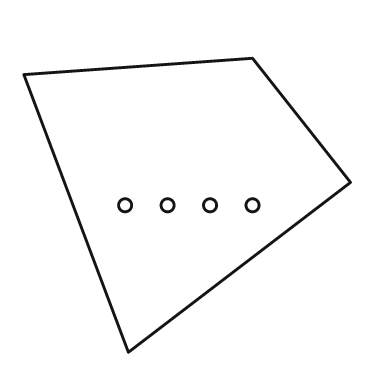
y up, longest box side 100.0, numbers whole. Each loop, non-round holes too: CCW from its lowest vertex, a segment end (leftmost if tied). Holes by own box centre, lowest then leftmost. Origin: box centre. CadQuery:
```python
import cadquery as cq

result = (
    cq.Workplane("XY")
    .moveTo(-18.0, -45.0)
    .lineTo(50.0, 7.0)
    .lineTo(20.0, 45.0)
    .lineTo(-50.0, 40.0)
    .close()
    .moveTo(-19.0, 0.0)
    .circle(2.0)
    .moveTo(-6.0, 0.0)
    .circle(2.0)
    .moveTo(7.0, 0.0)
    .circle(2.0)
    .moveTo(20.0, 0.0)
    .circle(2.0)
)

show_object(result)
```